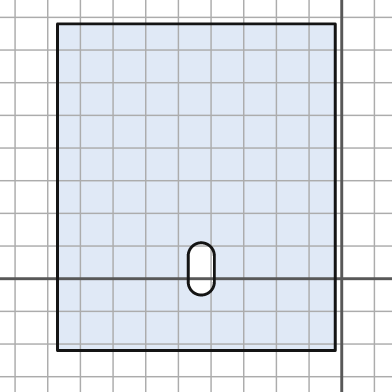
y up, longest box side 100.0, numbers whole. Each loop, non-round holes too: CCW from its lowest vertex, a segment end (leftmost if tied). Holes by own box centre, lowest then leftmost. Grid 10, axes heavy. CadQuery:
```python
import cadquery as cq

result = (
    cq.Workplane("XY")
    .moveTo(-87.0, -22.0)
    .lineTo(-2.0, -22.0)
    .lineTo(-2.0, 78.0)
    .lineTo(-87.0, 78.0)
    .close()
    .moveTo(-47.0, -1.0)
    .threePointArc((-43.0, -5.0), (-39.0, -1.0))
    .lineTo(-39.0, 7.0)
    .threePointArc((-43.0, 11.0), (-47.0, 7.0))
    .close()
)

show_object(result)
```